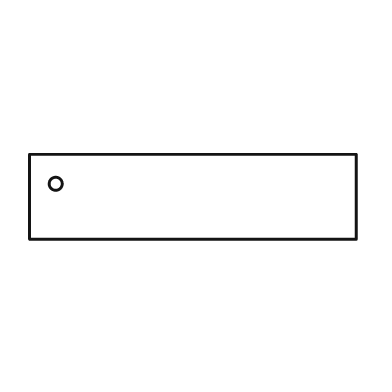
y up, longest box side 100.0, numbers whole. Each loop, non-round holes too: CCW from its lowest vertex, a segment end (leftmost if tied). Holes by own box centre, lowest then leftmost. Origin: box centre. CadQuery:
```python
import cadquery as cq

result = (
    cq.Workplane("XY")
    .moveTo(-50.0, -13.0)
    .lineTo(50.0, -13.0)
    .lineTo(50.0, 13.0)
    .lineTo(-50.0, 13.0)
    .close()
    .moveTo(-42.0, 4.0)
    .circle(2.0)
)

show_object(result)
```